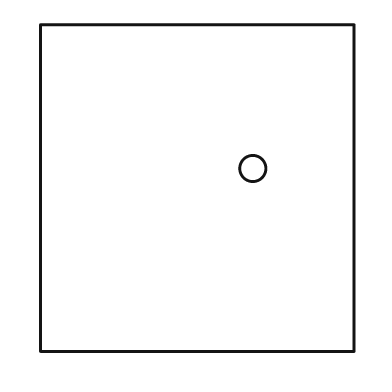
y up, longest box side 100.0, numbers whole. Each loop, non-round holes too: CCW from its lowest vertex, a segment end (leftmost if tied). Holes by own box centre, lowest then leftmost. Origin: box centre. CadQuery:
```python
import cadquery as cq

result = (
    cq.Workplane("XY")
    .moveTo(-48.0, -50.0)
    .lineTo(48.0, -50.0)
    .lineTo(48.0, 50.0)
    .lineTo(-48.0, 50.0)
    .close()
    .moveTo(17.0, 6.0)
    .circle(4.0)
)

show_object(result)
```